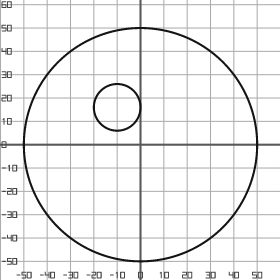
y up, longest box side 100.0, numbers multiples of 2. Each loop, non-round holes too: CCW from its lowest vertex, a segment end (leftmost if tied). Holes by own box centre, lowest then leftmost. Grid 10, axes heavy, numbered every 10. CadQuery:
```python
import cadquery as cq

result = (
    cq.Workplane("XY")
    .moveTo(0.0, 0.0)
    .circle(50.0)
    .moveTo(-10.0, 16.0)
    .circle(10.0)
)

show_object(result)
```